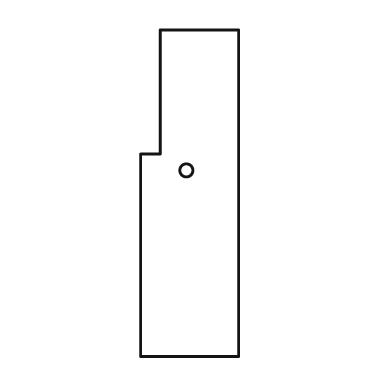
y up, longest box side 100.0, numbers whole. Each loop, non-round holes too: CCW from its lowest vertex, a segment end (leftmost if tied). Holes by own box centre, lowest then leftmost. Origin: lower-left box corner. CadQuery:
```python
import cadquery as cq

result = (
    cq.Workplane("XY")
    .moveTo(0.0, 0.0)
    .lineTo(30.0, 0.0)
    .lineTo(30.0, 100.0)
    .lineTo(6.0, 100.0)
    .lineTo(6.0, 62.0)
    .lineTo(0.0, 62.0)
    .close()
    .moveTo(14.0, 57.0)
    .circle(2.0)
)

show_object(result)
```